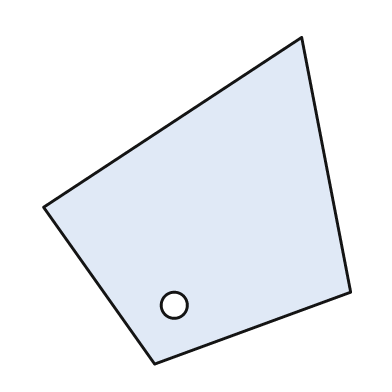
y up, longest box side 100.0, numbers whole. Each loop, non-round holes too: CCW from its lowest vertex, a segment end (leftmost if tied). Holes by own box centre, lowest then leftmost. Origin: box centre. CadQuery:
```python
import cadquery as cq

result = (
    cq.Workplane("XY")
    .moveTo(-13.0, -50.0)
    .lineTo(47.0, -28.0)
    .lineTo(32.0, 50.0)
    .lineTo(-47.0, -2.0)
    .close()
    .moveTo(-7.0, -32.0)
    .circle(4.0)
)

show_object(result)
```